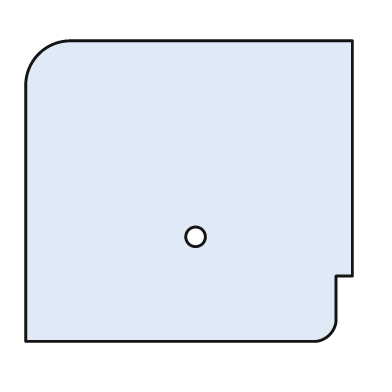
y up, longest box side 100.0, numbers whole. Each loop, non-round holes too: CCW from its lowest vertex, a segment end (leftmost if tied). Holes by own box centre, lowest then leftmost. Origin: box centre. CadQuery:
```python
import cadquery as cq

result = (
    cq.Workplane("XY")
    .moveTo(-50.0, -46.0)
    .lineTo(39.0, -46.0)
    .threePointArc((43.0, -44.0), (45.0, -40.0))
    .lineTo(45.0, -26.0)
    .lineTo(50.0, -26.0)
    .lineTo(50.0, 46.0)
    .lineTo(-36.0, 46.0)
    .threePointArc((-46.0, 42.0), (-50.0, 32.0))
    .close()
    .moveTo(2.0, -14.0)
    .circle(3.0)
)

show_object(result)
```